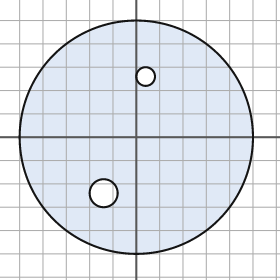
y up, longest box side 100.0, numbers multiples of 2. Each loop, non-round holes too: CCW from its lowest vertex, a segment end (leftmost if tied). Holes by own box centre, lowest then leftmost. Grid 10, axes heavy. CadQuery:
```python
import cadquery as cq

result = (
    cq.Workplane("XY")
    .moveTo(0.0, 0.0)
    .circle(50.0)
    .moveTo(-14.0, -24.0)
    .circle(6.0)
    .moveTo(4.0, 26.0)
    .circle(4.0)
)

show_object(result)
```